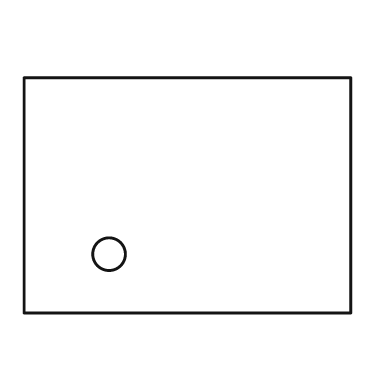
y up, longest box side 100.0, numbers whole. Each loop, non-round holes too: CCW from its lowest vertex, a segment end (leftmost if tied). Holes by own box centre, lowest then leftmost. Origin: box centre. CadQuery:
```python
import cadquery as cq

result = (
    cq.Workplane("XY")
    .moveTo(-50.0, -36.0)
    .lineTo(50.0, -36.0)
    .lineTo(50.0, 36.0)
    .lineTo(-50.0, 36.0)
    .close()
    .moveTo(-24.0, -18.0)
    .circle(5.0)
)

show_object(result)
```